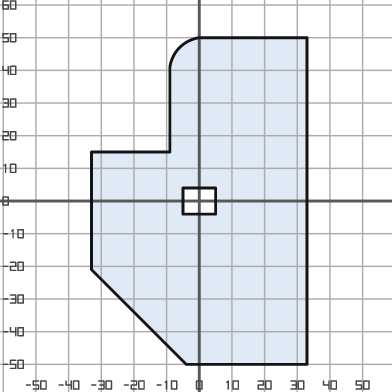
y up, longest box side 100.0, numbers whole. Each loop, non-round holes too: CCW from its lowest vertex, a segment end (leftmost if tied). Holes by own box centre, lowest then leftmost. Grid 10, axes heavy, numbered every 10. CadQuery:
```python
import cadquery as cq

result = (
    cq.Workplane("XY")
    .moveTo(-4.0, -50.0)
    .lineTo(33.0, -50.0)
    .lineTo(33.0, 50.0)
    .lineTo(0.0, 50.0)
    .threePointArc((-6.0, 47.0), (-9.0, 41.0))
    .lineTo(-9.0, 15.0)
    .lineTo(-33.0, 15.0)
    .lineTo(-33.0, -21.0)
    .close()
    .moveTo(-5.0, -4.0)
    .lineTo(5.0, -4.0)
    .lineTo(5.0, 4.0)
    .lineTo(-5.0, 4.0)
    .close()
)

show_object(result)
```